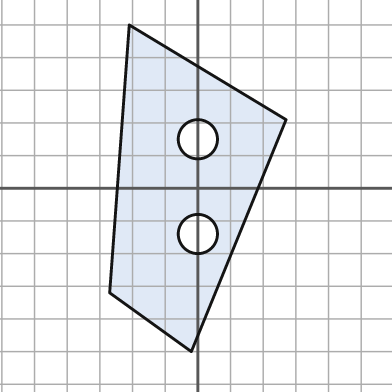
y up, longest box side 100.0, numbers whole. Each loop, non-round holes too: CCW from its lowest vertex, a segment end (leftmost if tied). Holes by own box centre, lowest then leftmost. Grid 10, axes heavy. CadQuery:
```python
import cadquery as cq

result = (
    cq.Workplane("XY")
    .moveTo(-2.0, -50.0)
    .lineTo(27.0, 21.0)
    .lineTo(-21.0, 50.0)
    .lineTo(-27.0, -32.0)
    .close()
    .moveTo(0.0, -14.0)
    .circle(6.0)
    .moveTo(0.0, 15.0)
    .circle(6.0)
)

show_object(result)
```